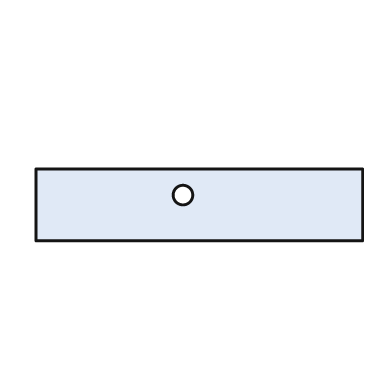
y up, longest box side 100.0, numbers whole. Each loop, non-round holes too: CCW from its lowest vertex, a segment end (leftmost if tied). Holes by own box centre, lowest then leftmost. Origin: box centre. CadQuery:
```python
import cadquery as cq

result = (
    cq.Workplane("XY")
    .moveTo(-50.0, -11.0)
    .lineTo(50.0, -11.0)
    .lineTo(50.0, 11.0)
    .lineTo(-50.0, 11.0)
    .close()
    .moveTo(-5.0, 3.0)
    .circle(3.0)
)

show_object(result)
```